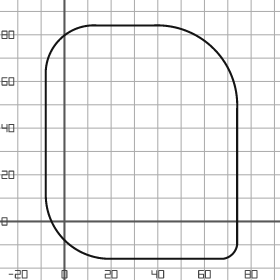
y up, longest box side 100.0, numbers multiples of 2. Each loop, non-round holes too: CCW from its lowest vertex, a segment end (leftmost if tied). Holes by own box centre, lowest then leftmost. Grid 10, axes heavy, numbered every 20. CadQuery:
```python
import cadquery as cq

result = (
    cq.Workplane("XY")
    .moveTo(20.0, -16.0)
    .lineTo(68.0, -16.0)
    .threePointArc((72.0, -14.0), (74.0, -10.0))
    .lineTo(74.0, 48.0)
    .threePointArc((64.0, 74.0), (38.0, 84.0))
    .lineTo(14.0, 84.0)
    .threePointArc((-2.0, 78.0), (-8.0, 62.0))
    .lineTo(-8.0, 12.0)
    .threePointArc((0.0, -8.0), (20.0, -16.0))
    .close()
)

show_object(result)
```